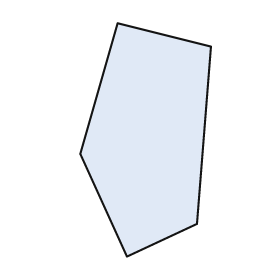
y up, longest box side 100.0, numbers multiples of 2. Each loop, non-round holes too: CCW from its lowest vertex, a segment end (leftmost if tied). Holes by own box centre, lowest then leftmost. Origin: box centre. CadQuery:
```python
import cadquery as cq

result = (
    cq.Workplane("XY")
    .moveTo(-8.0, -50.0)
    .lineTo(22.0, -36.0)
    .lineTo(28.0, 40.0)
    .lineTo(-12.0, 50.0)
    .lineTo(-28.0, -6.0)
    .close()
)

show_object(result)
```